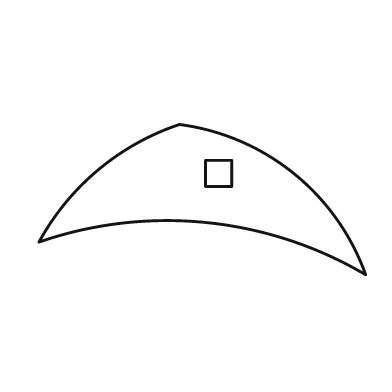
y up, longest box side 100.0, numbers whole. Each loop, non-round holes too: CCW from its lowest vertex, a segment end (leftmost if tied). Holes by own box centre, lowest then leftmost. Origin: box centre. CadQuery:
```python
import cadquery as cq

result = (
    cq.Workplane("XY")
    .moveTo(50.0, -23.0)
    .threePointArc((28.0, 8.0), (-7.0, 23.0))
    .threePointArc((-32.0, 9.0), (-50.0, -13.0))
    .threePointArc((1.0, -7.0), (50.0, -23.0))
    .close()
    .moveTo(1.0, 4.0)
    .lineTo(9.0, 4.0)
    .lineTo(9.0, 12.0)
    .lineTo(1.0, 12.0)
    .close()
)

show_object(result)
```